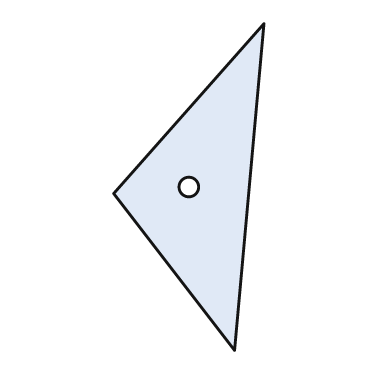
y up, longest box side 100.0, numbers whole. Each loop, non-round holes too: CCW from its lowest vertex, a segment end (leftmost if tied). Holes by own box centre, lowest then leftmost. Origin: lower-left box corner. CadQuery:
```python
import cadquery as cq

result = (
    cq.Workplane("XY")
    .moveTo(37.0, 0.0)
    .lineTo(46.0, 100.0)
    .lineTo(0.0, 48.0)
    .close()
    .moveTo(23.0, 50.0)
    .circle(3.0)
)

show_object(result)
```